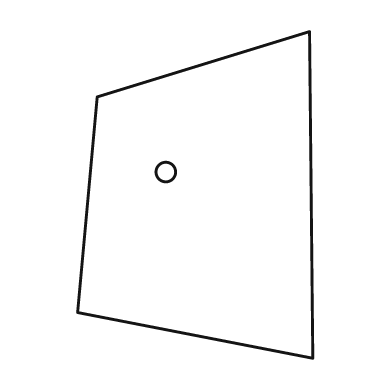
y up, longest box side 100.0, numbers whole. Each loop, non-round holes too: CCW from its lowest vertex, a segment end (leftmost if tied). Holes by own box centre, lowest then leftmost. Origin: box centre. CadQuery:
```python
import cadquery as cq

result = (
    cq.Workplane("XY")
    .moveTo(36.0, -50.0)
    .lineTo(35.0, 50.0)
    .lineTo(-30.0, 30.0)
    .lineTo(-36.0, -36.0)
    .close()
    .moveTo(-9.0, 7.0)
    .circle(3.0)
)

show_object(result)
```